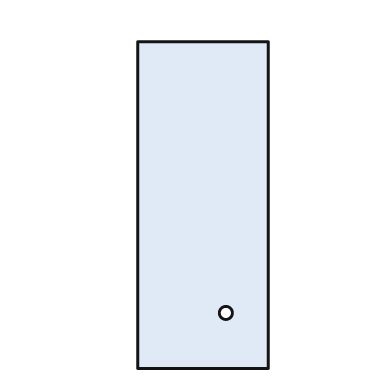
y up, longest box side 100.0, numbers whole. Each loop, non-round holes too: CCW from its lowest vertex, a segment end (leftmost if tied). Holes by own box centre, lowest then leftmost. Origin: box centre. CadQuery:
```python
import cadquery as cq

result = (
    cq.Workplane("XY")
    .moveTo(-20.0, -50.0)
    .lineTo(20.0, -50.0)
    .lineTo(20.0, 50.0)
    .lineTo(-20.0, 50.0)
    .close()
    .moveTo(7.0, -33.0)
    .circle(2.0)
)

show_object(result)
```